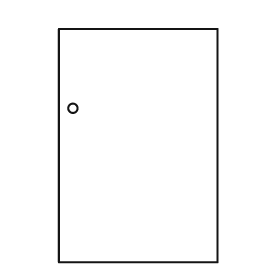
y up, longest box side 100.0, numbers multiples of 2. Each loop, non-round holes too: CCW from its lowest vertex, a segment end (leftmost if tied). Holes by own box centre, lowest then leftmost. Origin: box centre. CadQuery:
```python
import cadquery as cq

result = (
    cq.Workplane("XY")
    .moveTo(-34.0, -50.0)
    .lineTo(34.0, -50.0)
    .lineTo(34.0, 50.0)
    .lineTo(-34.0, 50.0)
    .close()
    .moveTo(-28.0, 16.0)
    .circle(2.0)
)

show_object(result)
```